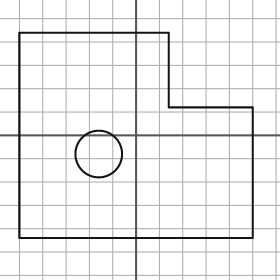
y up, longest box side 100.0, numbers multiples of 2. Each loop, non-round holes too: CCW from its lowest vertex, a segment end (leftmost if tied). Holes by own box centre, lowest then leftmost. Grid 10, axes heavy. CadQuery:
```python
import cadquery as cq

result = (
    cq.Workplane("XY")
    .moveTo(-50.0, -44.0)
    .lineTo(50.0, -44.0)
    .lineTo(50.0, 12.0)
    .lineTo(14.0, 12.0)
    .lineTo(14.0, 44.0)
    .lineTo(-50.0, 44.0)
    .close()
    .moveTo(-16.0, -8.0)
    .circle(10.0)
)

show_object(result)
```